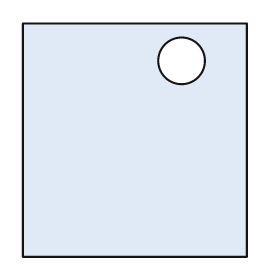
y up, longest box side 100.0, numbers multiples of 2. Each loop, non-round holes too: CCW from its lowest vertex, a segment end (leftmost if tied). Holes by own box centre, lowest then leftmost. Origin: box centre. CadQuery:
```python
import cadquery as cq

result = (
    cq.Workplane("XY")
    .moveTo(-48.0, -50.0)
    .lineTo(48.0, -50.0)
    .lineTo(48.0, 50.0)
    .lineTo(-48.0, 50.0)
    .close()
    .moveTo(20.0, 34.0)
    .circle(10.0)
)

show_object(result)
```